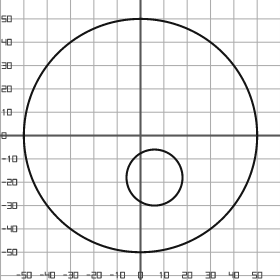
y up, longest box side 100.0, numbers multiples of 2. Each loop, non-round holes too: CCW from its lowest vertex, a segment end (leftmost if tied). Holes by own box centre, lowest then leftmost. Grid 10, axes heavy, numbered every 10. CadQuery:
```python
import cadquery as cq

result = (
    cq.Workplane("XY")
    .moveTo(0.0, 0.0)
    .circle(50.0)
    .moveTo(6.0, -18.0)
    .circle(12.0)
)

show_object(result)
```